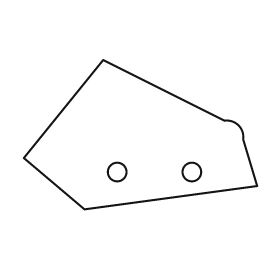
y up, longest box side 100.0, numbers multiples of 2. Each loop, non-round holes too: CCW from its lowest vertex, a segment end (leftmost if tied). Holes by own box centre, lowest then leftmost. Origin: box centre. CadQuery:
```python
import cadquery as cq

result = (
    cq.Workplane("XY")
    .moveTo(-24.0, -32.0)
    .lineTo(50.0, -22.0)
    .lineTo(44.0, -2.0)
    .threePointArc((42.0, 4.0), (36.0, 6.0))
    .lineTo(-16.0, 32.0)
    .lineTo(-50.0, -10.0)
    .close()
    .moveTo(-10.0, -16.0)
    .circle(4.0)
    .moveTo(22.0, -16.0)
    .circle(4.0)
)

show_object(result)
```